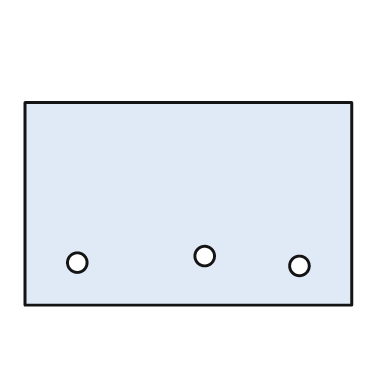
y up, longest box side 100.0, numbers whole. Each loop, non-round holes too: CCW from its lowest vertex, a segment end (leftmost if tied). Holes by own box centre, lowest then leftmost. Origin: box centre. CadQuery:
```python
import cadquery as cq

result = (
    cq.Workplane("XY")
    .moveTo(-50.0, -31.0)
    .lineTo(50.0, -31.0)
    .lineTo(50.0, 31.0)
    .lineTo(-50.0, 31.0)
    .close()
    .moveTo(34.0, -19.0)
    .circle(3.0)
    .moveTo(-34.0, -18.0)
    .circle(3.0)
    .moveTo(5.0, -16.0)
    .circle(3.0)
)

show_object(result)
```